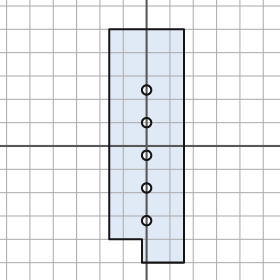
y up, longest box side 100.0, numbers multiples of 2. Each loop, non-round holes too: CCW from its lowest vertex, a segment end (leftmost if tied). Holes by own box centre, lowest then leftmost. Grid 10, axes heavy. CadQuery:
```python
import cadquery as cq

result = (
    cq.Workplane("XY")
    .moveTo(-2.0, -50.0)
    .lineTo(16.0, -50.0)
    .lineTo(16.0, 50.0)
    .lineTo(-16.0, 50.0)
    .lineTo(-16.0, -40.0)
    .lineTo(-2.0, -40.0)
    .close()
    .moveTo(0.0, -32.0)
    .circle(2.0)
    .moveTo(0.0, -18.0)
    .circle(2.0)
    .moveTo(0.0, -4.0)
    .circle(2.0)
    .moveTo(0.0, 10.0)
    .circle(2.0)
    .moveTo(0.0, 24.0)
    .circle(2.0)
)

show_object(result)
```